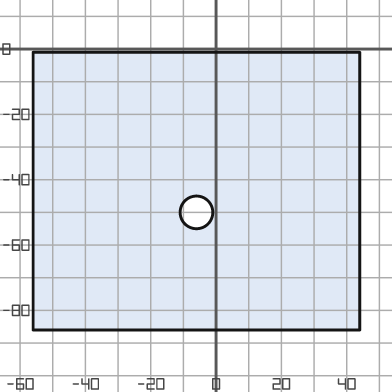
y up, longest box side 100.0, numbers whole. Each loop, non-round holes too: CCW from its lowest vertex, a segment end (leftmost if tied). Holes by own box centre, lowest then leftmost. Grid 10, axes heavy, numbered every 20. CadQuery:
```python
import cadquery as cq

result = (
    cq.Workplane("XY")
    .moveTo(-56.0, -86.0)
    .lineTo(44.0, -86.0)
    .lineTo(44.0, -1.0)
    .lineTo(-56.0, -1.0)
    .close()
    .moveTo(-6.0, -50.0)
    .circle(5.0)
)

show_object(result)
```